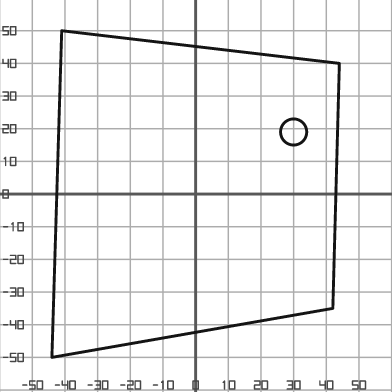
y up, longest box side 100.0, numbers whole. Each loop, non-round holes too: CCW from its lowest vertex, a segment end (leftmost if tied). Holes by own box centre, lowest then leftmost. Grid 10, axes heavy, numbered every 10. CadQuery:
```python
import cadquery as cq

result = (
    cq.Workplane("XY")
    .moveTo(-44.0, -50.0)
    .lineTo(42.0, -35.0)
    .lineTo(44.0, 40.0)
    .lineTo(-41.0, 50.0)
    .close()
    .moveTo(30.0, 19.0)
    .circle(4.0)
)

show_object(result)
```